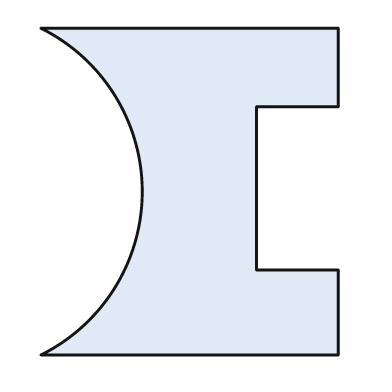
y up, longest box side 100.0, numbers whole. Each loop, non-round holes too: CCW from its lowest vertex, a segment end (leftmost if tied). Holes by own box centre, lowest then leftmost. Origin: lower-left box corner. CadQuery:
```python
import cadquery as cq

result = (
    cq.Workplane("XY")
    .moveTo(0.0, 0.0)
    .lineTo(91.0, 0.0)
    .lineTo(91.0, 26.0)
    .lineTo(66.0, 26.0)
    .lineTo(66.0, 76.0)
    .lineTo(91.0, 76.0)
    .lineTo(91.0, 100.0)
    .lineTo(0.0, 100.0)
    .threePointArc((31.0, 50.0), (0.0, 0.0))
    .close()
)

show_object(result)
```